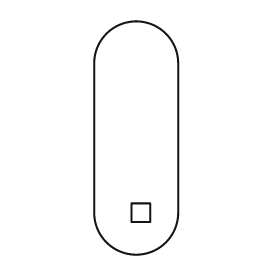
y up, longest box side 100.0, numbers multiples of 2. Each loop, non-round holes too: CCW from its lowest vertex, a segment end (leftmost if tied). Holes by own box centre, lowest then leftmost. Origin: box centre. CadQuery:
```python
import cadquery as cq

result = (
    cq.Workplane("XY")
    .moveTo(-18.0, -32.0)
    .threePointArc((0.0, -50.0), (18.0, -32.0))
    .lineTo(18.0, 32.0)
    .threePointArc((0.0, 50.0), (-18.0, 32.0))
    .close()
    .moveTo(-2.0, -36.0)
    .lineTo(6.0, -36.0)
    .lineTo(6.0, -28.0)
    .lineTo(-2.0, -28.0)
    .close()
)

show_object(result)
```